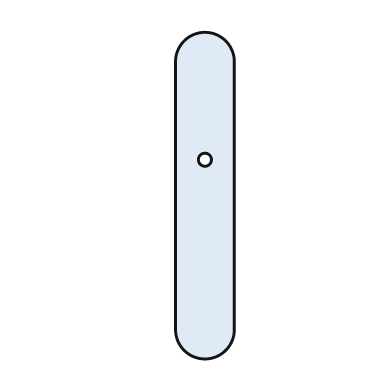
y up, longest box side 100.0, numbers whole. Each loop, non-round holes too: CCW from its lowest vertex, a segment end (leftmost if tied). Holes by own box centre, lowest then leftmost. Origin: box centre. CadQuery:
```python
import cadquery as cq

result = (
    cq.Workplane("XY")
    .moveTo(-9.0, -41.0)
    .threePointArc((0.0, -50.0), (9.0, -41.0))
    .lineTo(9.0, 41.0)
    .threePointArc((0.0, 50.0), (-9.0, 41.0))
    .close()
    .moveTo(0.0, 11.0)
    .circle(2.0)
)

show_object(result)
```